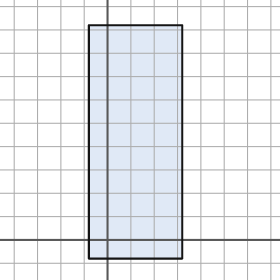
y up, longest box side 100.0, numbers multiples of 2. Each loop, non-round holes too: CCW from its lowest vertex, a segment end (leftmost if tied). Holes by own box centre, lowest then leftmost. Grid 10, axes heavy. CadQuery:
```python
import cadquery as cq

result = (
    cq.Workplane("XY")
    .moveTo(-8.0, -8.0)
    .lineTo(32.0, -8.0)
    .lineTo(32.0, 92.0)
    .lineTo(-8.0, 92.0)
    .close()
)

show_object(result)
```